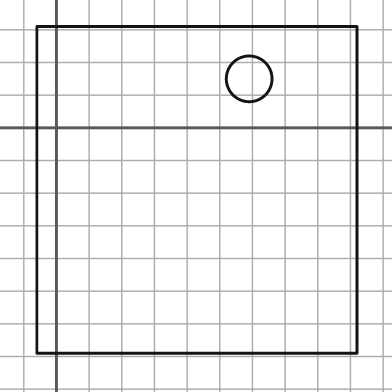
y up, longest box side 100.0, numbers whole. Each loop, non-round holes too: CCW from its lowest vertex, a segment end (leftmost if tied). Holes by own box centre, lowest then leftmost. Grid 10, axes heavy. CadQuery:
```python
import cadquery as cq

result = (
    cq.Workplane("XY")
    .moveTo(-6.0, -69.0)
    .lineTo(92.0, -69.0)
    .lineTo(92.0, 31.0)
    .lineTo(-6.0, 31.0)
    .close()
    .moveTo(59.0, 15.0)
    .circle(7.0)
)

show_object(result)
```